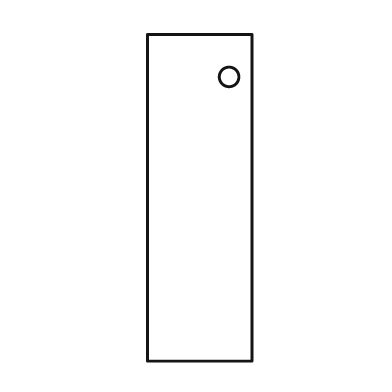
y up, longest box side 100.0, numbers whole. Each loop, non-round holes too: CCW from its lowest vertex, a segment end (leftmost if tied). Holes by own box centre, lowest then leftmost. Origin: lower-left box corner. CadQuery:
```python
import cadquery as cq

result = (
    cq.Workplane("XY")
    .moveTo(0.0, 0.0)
    .lineTo(32.0, 0.0)
    .lineTo(32.0, 100.0)
    .lineTo(0.0, 100.0)
    .close()
    .moveTo(25.0, 87.0)
    .circle(3.0)
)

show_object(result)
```